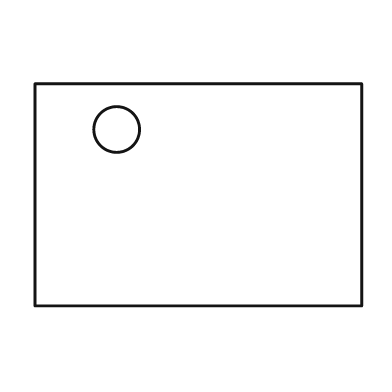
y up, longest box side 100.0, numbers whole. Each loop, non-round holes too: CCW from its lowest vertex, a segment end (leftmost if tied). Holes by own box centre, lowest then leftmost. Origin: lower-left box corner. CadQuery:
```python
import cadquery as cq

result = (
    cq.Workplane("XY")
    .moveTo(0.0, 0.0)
    .lineTo(100.0, 0.0)
    .lineTo(100.0, 68.0)
    .lineTo(0.0, 68.0)
    .close()
    .moveTo(25.0, 54.0)
    .circle(7.0)
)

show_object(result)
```